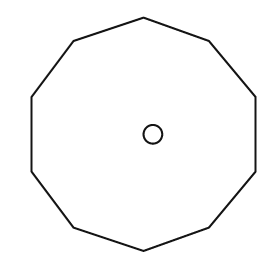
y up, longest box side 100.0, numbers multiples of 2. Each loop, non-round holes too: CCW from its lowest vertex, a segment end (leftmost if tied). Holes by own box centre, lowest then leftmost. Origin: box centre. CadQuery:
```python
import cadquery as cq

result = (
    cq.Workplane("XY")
    .moveTo(0.0, -50.0)
    .lineTo(28.0, -40.0)
    .lineTo(48.0, -16.0)
    .lineTo(48.0, 16.0)
    .lineTo(28.0, 40.0)
    .lineTo(0.0, 50.0)
    .lineTo(-30.0, 40.0)
    .lineTo(-48.0, 16.0)
    .lineTo(-48.0, -16.0)
    .lineTo(-30.0, -40.0)
    .close()
    .moveTo(4.0, 0.0)
    .circle(4.0)
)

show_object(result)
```